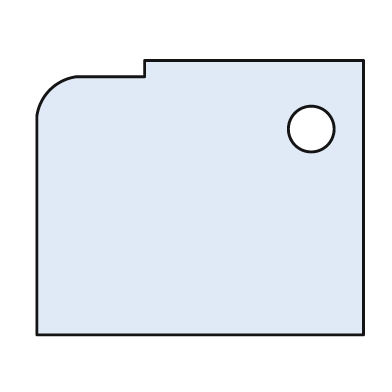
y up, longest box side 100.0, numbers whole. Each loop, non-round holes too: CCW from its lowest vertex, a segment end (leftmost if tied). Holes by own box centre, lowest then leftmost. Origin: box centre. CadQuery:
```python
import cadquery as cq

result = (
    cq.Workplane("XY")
    .moveTo(-50.0, -42.0)
    .lineTo(50.0, -42.0)
    .lineTo(50.0, 42.0)
    .lineTo(-17.0, 42.0)
    .lineTo(-17.0, 37.0)
    .lineTo(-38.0, 37.0)
    .threePointArc((-46.0, 33.0), (-50.0, 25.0))
    .close()
    .moveTo(34.0, 21.0)
    .circle(7.0)
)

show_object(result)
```